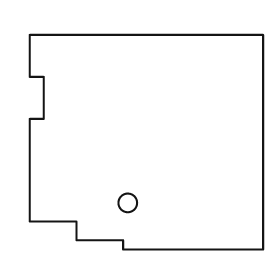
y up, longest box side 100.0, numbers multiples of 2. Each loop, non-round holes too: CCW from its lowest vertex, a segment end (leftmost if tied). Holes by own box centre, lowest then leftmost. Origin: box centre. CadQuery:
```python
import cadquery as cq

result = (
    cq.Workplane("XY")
    .moveTo(-10.0, -46.0)
    .lineTo(50.0, -46.0)
    .lineTo(50.0, 46.0)
    .lineTo(-50.0, 46.0)
    .lineTo(-50.0, 28.0)
    .lineTo(-44.0, 28.0)
    .lineTo(-44.0, 10.0)
    .lineTo(-50.0, 10.0)
    .lineTo(-50.0, -34.0)
    .lineTo(-30.0, -34.0)
    .lineTo(-30.0, -42.0)
    .lineTo(-10.0, -42.0)
    .close()
    .moveTo(-8.0, -26.0)
    .circle(4.0)
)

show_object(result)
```